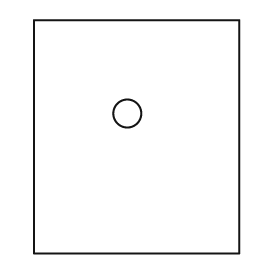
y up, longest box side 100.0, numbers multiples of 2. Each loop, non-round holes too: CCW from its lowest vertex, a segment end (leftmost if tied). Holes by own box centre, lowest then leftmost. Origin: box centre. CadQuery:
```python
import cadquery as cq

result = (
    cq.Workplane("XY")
    .moveTo(-44.0, -50.0)
    .lineTo(44.0, -50.0)
    .lineTo(44.0, 50.0)
    .lineTo(-44.0, 50.0)
    .close()
    .moveTo(-4.0, 10.0)
    .circle(6.0)
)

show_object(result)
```